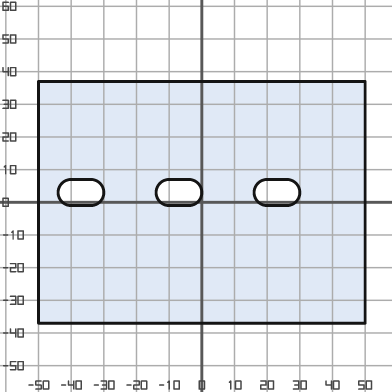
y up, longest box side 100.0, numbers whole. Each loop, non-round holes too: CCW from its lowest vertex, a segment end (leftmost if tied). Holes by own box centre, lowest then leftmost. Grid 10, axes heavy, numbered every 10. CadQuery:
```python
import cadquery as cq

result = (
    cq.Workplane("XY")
    .moveTo(-50.0, -37.0)
    .lineTo(50.0, -37.0)
    .lineTo(50.0, 37.0)
    .lineTo(-50.0, 37.0)
    .close()
    .moveTo(-40.0, -1.0)
    .lineTo(-34.0, -1.0)
    .threePointArc((-30.0, 3.0), (-34.0, 7.0))
    .lineTo(-40.0, 7.0)
    .threePointArc((-44.0, 3.0), (-40.0, -1.0))
    .close()
    .moveTo(-10.0, -1.0)
    .lineTo(-4.0, -1.0)
    .threePointArc((0.0, 3.0), (-4.0, 7.0))
    .lineTo(-10.0, 7.0)
    .threePointArc((-14.0, 3.0), (-10.0, -1.0))
    .close()
    .moveTo(20.0, -1.0)
    .lineTo(26.0, -1.0)
    .threePointArc((30.0, 3.0), (26.0, 7.0))
    .lineTo(20.0, 7.0)
    .threePointArc((16.0, 3.0), (20.0, -1.0))
    .close()
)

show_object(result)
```